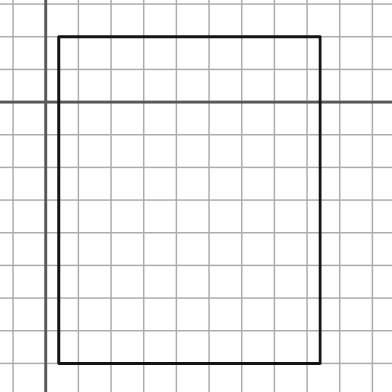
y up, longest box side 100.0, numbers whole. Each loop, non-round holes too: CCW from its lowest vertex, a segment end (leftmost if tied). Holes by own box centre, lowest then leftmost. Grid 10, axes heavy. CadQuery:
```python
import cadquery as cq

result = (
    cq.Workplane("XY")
    .moveTo(4.0, -80.0)
    .lineTo(84.0, -80.0)
    .lineTo(84.0, 20.0)
    .lineTo(4.0, 20.0)
    .close()
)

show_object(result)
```